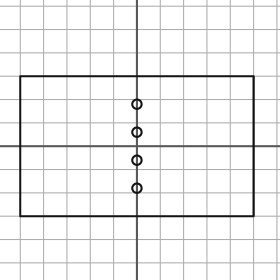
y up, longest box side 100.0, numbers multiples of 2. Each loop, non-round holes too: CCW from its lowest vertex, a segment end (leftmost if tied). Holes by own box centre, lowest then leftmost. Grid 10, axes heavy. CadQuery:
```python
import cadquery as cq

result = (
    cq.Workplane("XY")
    .moveTo(-50.0, -30.0)
    .lineTo(50.0, -30.0)
    .lineTo(50.0, 30.0)
    .lineTo(-50.0, 30.0)
    .close()
    .moveTo(0.0, -18.0)
    .circle(2.0)
    .moveTo(0.0, -6.0)
    .circle(2.0)
    .moveTo(0.0, 6.0)
    .circle(2.0)
    .moveTo(0.0, 18.0)
    .circle(2.0)
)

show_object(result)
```